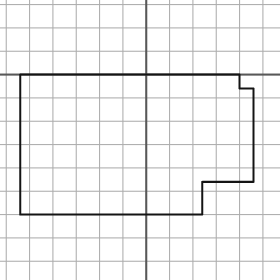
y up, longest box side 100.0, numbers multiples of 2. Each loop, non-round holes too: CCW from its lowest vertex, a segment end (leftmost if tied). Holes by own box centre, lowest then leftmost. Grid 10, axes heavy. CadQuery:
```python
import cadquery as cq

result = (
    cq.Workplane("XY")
    .moveTo(-54.0, -60.0)
    .lineTo(24.0, -60.0)
    .lineTo(24.0, -46.0)
    .lineTo(46.0, -46.0)
    .lineTo(46.0, -6.0)
    .lineTo(40.0, -6.0)
    .lineTo(40.0, 0.0)
    .lineTo(-54.0, 0.0)
    .close()
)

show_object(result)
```